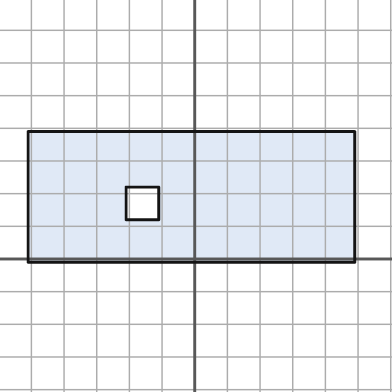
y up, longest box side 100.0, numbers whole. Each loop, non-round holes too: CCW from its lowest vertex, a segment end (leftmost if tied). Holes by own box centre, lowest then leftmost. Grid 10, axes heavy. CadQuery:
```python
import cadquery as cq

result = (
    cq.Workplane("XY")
    .moveTo(-51.0, -1.0)
    .lineTo(49.0, -1.0)
    .lineTo(49.0, 39.0)
    .lineTo(-51.0, 39.0)
    .close()
    .moveTo(-21.0, 12.0)
    .lineTo(-11.0, 12.0)
    .lineTo(-11.0, 22.0)
    .lineTo(-21.0, 22.0)
    .close()
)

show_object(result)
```